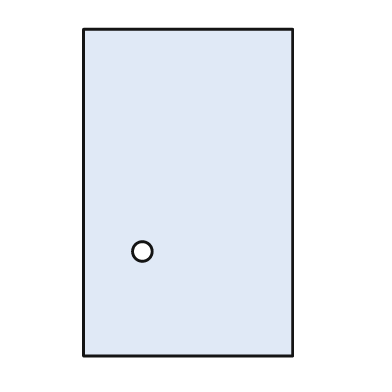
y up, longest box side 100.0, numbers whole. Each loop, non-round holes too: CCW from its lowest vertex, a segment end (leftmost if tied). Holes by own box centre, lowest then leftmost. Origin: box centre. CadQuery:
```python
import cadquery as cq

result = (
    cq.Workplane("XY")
    .moveTo(-32.0, -50.0)
    .lineTo(32.0, -50.0)
    .lineTo(32.0, 50.0)
    .lineTo(-32.0, 50.0)
    .close()
    .moveTo(-14.0, -18.0)
    .circle(3.0)
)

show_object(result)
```